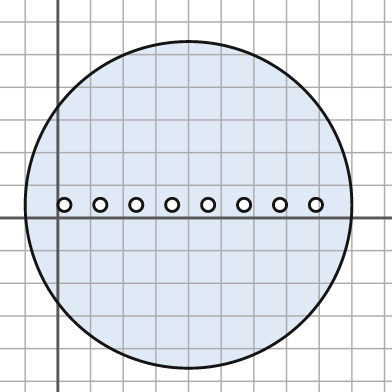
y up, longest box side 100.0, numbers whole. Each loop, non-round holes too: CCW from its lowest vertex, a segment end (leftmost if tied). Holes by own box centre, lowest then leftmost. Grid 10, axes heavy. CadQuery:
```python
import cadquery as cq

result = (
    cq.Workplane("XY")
    .moveTo(40.0, 4.0)
    .circle(50.0)
    .moveTo(2.0, 4.0)
    .circle(2.0)
    .moveTo(13.0, 4.0)
    .circle(2.0)
    .moveTo(24.0, 4.0)
    .circle(2.0)
    .moveTo(35.0, 4.0)
    .circle(2.0)
    .moveTo(46.0, 4.0)
    .circle(2.0)
    .moveTo(57.0, 4.0)
    .circle(2.0)
    .moveTo(68.0, 4.0)
    .circle(2.0)
    .moveTo(79.0, 4.0)
    .circle(2.0)
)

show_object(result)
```